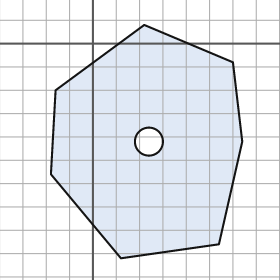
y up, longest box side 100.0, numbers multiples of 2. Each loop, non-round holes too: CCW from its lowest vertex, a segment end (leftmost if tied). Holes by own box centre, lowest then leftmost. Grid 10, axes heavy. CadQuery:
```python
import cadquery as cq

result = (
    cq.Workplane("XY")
    .moveTo(12.0, -92.0)
    .lineTo(54.0, -86.0)
    .lineTo(64.0, -42.0)
    .lineTo(60.0, -8.0)
    .lineTo(22.0, 8.0)
    .lineTo(-16.0, -20.0)
    .lineTo(-18.0, -56.0)
    .close()
    .moveTo(24.0, -42.0)
    .circle(6.0)
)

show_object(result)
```